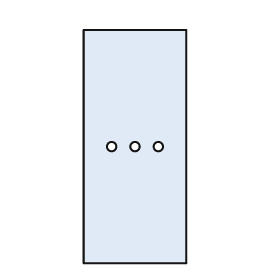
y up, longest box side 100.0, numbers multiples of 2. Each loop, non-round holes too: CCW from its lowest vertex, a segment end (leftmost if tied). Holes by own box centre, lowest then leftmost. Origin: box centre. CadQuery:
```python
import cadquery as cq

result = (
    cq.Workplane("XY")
    .moveTo(-22.0, -50.0)
    .lineTo(22.0, -50.0)
    .lineTo(22.0, 50.0)
    .lineTo(-22.0, 50.0)
    .close()
    .moveTo(-10.0, 0.0)
    .circle(2.0)
    .moveTo(0.0, 0.0)
    .circle(2.0)
    .moveTo(10.0, 0.0)
    .circle(2.0)
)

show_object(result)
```